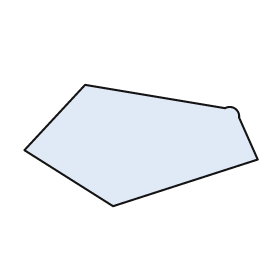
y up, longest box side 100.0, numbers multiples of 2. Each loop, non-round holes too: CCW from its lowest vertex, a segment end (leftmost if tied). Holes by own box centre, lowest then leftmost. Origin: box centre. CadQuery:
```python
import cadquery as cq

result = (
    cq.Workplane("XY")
    .moveTo(-12.0, -26.0)
    .lineTo(50.0, -6.0)
    .lineTo(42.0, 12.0)
    .threePointArc((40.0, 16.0), (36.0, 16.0))
    .lineTo(-24.0, 26.0)
    .lineTo(-50.0, -2.0)
    .close()
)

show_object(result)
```